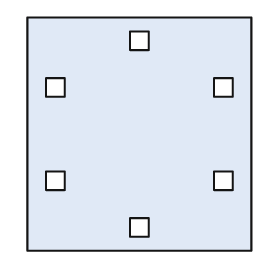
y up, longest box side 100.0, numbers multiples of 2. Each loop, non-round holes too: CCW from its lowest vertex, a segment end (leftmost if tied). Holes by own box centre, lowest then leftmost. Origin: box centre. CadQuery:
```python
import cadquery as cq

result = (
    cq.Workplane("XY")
    .moveTo(-48.0, -50.0)
    .lineTo(48.0, -50.0)
    .lineTo(48.0, 50.0)
    .lineTo(-48.0, 50.0)
    .close()
    .moveTo(-4.0, -44.0)
    .lineTo(4.0, -44.0)
    .lineTo(4.0, -36.0)
    .lineTo(-4.0, -36.0)
    .close()
    .moveTo(-40.0, -24.0)
    .lineTo(-32.0, -24.0)
    .lineTo(-32.0, -16.0)
    .lineTo(-40.0, -16.0)
    .close()
    .moveTo(32.0, -24.0)
    .lineTo(40.0, -24.0)
    .lineTo(40.0, -16.0)
    .lineTo(32.0, -16.0)
    .close()
    .moveTo(-40.0, 16.0)
    .lineTo(-32.0, 16.0)
    .lineTo(-32.0, 24.0)
    .lineTo(-40.0, 24.0)
    .close()
    .moveTo(32.0, 16.0)
    .lineTo(40.0, 16.0)
    .lineTo(40.0, 24.0)
    .lineTo(32.0, 24.0)
    .close()
    .moveTo(-4.0, 36.0)
    .lineTo(4.0, 36.0)
    .lineTo(4.0, 44.0)
    .lineTo(-4.0, 44.0)
    .close()
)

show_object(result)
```